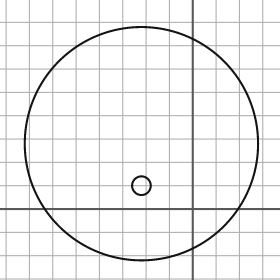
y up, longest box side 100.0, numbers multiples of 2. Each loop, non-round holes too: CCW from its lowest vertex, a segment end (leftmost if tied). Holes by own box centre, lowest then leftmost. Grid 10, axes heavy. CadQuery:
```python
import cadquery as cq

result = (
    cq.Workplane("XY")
    .moveTo(-22.0, 28.0)
    .circle(50.0)
    .moveTo(-22.0, 10.0)
    .circle(4.0)
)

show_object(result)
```